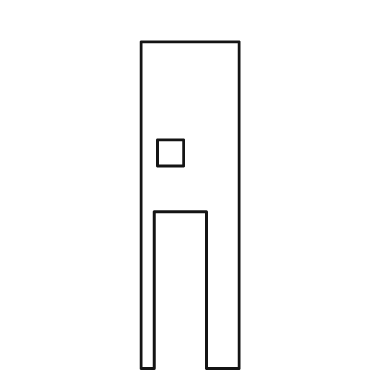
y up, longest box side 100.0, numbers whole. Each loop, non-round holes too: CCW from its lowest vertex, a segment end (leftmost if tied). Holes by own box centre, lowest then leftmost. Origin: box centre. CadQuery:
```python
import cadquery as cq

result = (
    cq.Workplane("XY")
    .moveTo(-15.0, -50.0)
    .lineTo(-11.0, -50.0)
    .lineTo(-11.0, -2.0)
    .lineTo(5.0, -2.0)
    .lineTo(5.0, -50.0)
    .lineTo(15.0, -50.0)
    .lineTo(15.0, 50.0)
    .lineTo(-15.0, 50.0)
    .close()
    .moveTo(-10.0, 12.0)
    .lineTo(-2.0, 12.0)
    .lineTo(-2.0, 20.0)
    .lineTo(-10.0, 20.0)
    .close()
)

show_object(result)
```